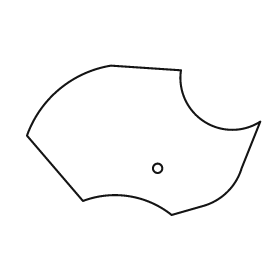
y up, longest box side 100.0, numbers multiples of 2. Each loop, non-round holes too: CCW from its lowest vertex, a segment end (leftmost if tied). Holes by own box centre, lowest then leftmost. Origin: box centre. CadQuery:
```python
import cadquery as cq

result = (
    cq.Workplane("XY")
    .moveTo(12.0, -32.0)
    .lineTo(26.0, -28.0)
    .threePointArc((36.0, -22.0), (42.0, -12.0))
    .lineTo(50.0, 8.0)
    .threePointArc((26.0, 8.0), (16.0, 30.0))
    .lineTo(-14.0, 32.0)
    .threePointArc((-36.0, 22.0), (-50.0, 2.0))
    .lineTo(-26.0, -26.0)
    .threePointArc((-6.0, -24.0), (12.0, -32.0))
    .close()
    .moveTo(6.0, -12.0)
    .circle(2.0)
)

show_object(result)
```